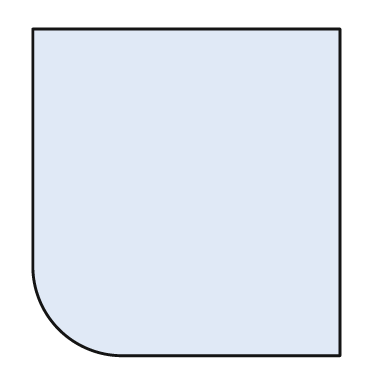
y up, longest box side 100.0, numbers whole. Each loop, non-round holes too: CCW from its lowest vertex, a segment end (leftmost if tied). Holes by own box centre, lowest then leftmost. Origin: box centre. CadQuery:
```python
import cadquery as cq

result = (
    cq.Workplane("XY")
    .moveTo(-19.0, -50.0)
    .lineTo(47.0, -50.0)
    .lineTo(47.0, 50.0)
    .lineTo(-47.0, 50.0)
    .lineTo(-47.0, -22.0)
    .threePointArc((-39.0, -42.0), (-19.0, -50.0))
    .close()
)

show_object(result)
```